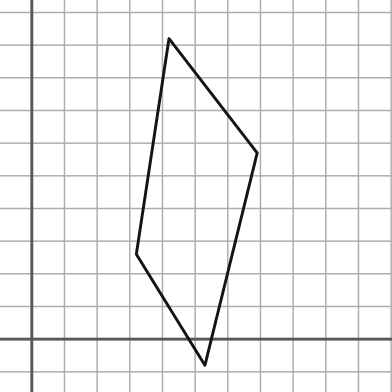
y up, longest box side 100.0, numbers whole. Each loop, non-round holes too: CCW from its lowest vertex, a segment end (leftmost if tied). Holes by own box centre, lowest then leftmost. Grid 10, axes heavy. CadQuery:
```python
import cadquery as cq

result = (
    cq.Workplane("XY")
    .moveTo(53.0, -8.0)
    .lineTo(69.0, 57.0)
    .lineTo(42.0, 92.0)
    .lineTo(32.0, 26.0)
    .close()
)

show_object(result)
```